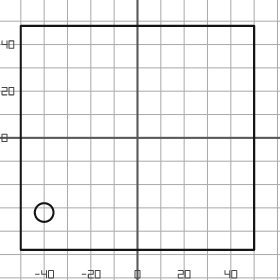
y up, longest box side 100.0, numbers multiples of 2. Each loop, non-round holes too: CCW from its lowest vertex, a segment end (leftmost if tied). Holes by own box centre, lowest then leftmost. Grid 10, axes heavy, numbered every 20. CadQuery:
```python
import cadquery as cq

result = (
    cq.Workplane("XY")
    .moveTo(-50.0, -48.0)
    .lineTo(50.0, -48.0)
    .lineTo(50.0, 48.0)
    .lineTo(-50.0, 48.0)
    .close()
    .moveTo(-40.0, -32.0)
    .circle(4.0)
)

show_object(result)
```